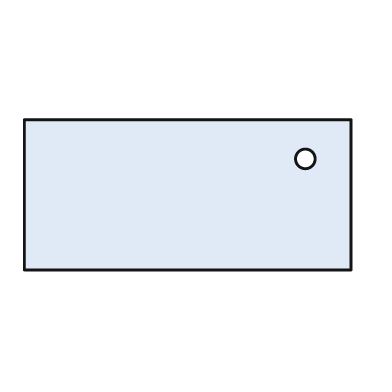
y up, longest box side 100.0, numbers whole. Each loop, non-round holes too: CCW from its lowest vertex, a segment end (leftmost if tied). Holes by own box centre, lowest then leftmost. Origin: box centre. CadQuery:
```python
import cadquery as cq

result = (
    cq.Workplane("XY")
    .moveTo(-50.0, -23.0)
    .lineTo(50.0, -23.0)
    .lineTo(50.0, 23.0)
    .lineTo(-50.0, 23.0)
    .close()
    .moveTo(36.0, 11.0)
    .circle(3.0)
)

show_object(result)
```